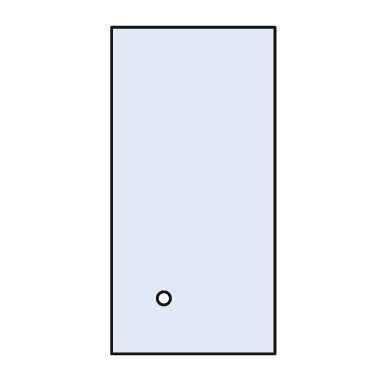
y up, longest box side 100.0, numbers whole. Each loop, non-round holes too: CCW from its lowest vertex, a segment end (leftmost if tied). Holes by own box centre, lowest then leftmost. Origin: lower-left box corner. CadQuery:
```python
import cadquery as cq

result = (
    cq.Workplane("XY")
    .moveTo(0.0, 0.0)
    .lineTo(50.0, 0.0)
    .lineTo(50.0, 100.0)
    .lineTo(0.0, 100.0)
    .close()
    .moveTo(16.0, 17.0)
    .circle(2.0)
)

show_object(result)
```